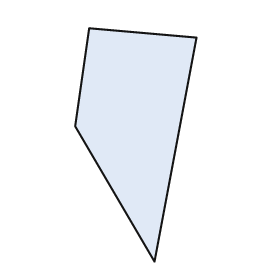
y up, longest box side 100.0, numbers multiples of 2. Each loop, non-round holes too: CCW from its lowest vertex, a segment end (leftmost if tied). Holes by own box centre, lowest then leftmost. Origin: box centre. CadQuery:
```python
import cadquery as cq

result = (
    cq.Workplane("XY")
    .moveTo(8.0, -50.0)
    .lineTo(26.0, 46.0)
    .lineTo(-20.0, 50.0)
    .lineTo(-26.0, 8.0)
    .close()
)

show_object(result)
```